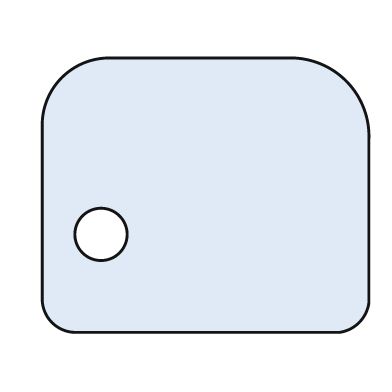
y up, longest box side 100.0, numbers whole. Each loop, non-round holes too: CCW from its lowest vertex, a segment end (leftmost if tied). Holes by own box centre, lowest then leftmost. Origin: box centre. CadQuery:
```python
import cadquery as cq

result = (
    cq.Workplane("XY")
    .moveTo(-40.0, -42.0)
    .lineTo(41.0, -42.0)
    .threePointArc((47.0, -39.0), (50.0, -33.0))
    .lineTo(50.0, 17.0)
    .threePointArc((43.0, 35.0), (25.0, 42.0))
    .lineTo(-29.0, 42.0)
    .threePointArc((-44.0, 36.0), (-50.0, 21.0))
    .lineTo(-50.0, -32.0)
    .threePointArc((-47.0, -39.0), (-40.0, -42.0))
    .close()
    .moveTo(-32.0, -12.0)
    .circle(8.0)
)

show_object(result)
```